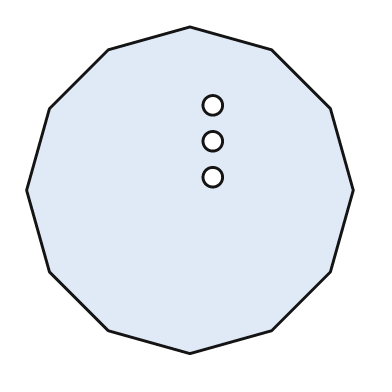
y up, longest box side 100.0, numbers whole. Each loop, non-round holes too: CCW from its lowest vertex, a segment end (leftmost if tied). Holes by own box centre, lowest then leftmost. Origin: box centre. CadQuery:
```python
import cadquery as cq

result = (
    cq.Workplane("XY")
    .moveTo(0.0, -50.0)
    .lineTo(25.0, -43.0)
    .lineTo(43.0, -25.0)
    .lineTo(50.0, 0.0)
    .lineTo(43.0, 25.0)
    .lineTo(25.0, 43.0)
    .lineTo(0.0, 50.0)
    .lineTo(-25.0, 43.0)
    .lineTo(-43.0, 25.0)
    .lineTo(-50.0, 0.0)
    .lineTo(-43.0, -25.0)
    .lineTo(-25.0, -43.0)
    .close()
    .moveTo(7.0, 4.0)
    .circle(3.0)
    .moveTo(7.0, 15.0)
    .circle(3.0)
    .moveTo(7.0, 26.0)
    .circle(3.0)
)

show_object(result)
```